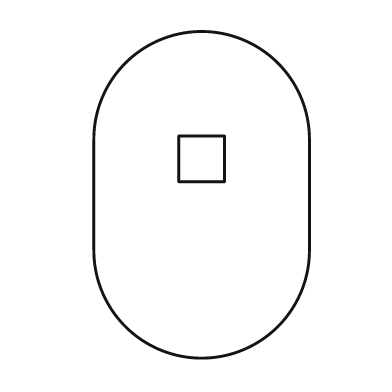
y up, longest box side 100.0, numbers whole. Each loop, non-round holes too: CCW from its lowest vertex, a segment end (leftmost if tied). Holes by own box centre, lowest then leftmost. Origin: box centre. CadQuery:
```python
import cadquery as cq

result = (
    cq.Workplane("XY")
    .moveTo(-33.0, -17.0)
    .threePointArc((0.0, -50.0), (33.0, -17.0))
    .lineTo(33.0, 17.0)
    .threePointArc((0.0, 50.0), (-33.0, 17.0))
    .close()
    .moveTo(-7.0, 4.0)
    .lineTo(7.0, 4.0)
    .lineTo(7.0, 18.0)
    .lineTo(-7.0, 18.0)
    .close()
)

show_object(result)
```